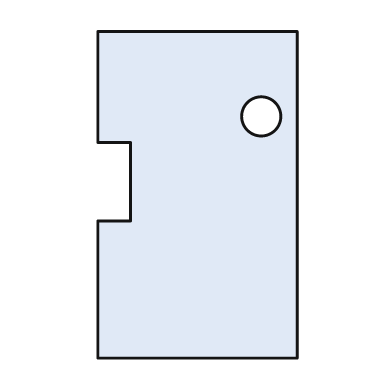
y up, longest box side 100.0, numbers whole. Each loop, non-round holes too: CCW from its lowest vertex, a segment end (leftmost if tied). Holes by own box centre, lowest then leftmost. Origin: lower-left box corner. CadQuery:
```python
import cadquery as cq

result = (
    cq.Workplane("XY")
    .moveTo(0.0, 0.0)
    .lineTo(61.0, 0.0)
    .lineTo(61.0, 100.0)
    .lineTo(0.0, 100.0)
    .lineTo(0.0, 66.0)
    .lineTo(10.0, 66.0)
    .lineTo(10.0, 42.0)
    .lineTo(0.0, 42.0)
    .close()
    .moveTo(50.0, 74.0)
    .circle(6.0)
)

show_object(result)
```